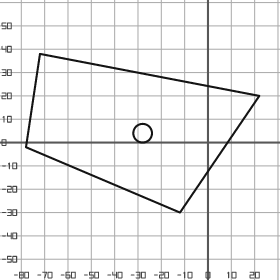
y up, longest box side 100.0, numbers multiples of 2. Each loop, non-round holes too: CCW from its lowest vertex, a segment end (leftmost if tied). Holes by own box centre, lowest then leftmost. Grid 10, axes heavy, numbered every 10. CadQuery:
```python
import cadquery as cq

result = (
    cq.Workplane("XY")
    .moveTo(-12.0, -30.0)
    .lineTo(22.0, 20.0)
    .lineTo(-72.0, 38.0)
    .lineTo(-78.0, -2.0)
    .close()
    .moveTo(-28.0, 4.0)
    .circle(4.0)
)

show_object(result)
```